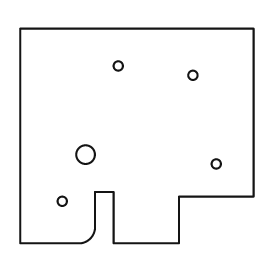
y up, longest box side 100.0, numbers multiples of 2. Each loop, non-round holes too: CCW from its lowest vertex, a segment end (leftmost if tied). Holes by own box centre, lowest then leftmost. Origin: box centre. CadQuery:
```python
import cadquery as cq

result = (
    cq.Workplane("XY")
    .moveTo(-50.0, -46.0)
    .lineTo(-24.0, -46.0)
    .threePointArc((-20.0, -44.0), (-18.0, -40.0))
    .lineTo(-18.0, -24.0)
    .lineTo(-10.0, -24.0)
    .lineTo(-10.0, -46.0)
    .lineTo(18.0, -46.0)
    .lineTo(18.0, -26.0)
    .lineTo(50.0, -26.0)
    .lineTo(50.0, 46.0)
    .lineTo(-50.0, 46.0)
    .close()
    .moveTo(-32.0, -28.0)
    .circle(2.0)
    .moveTo(34.0, -12.0)
    .circle(2.0)
    .moveTo(-22.0, -8.0)
    .circle(4.0)
    .moveTo(24.0, 26.0)
    .circle(2.0)
    .moveTo(-8.0, 30.0)
    .circle(2.0)
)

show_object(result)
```